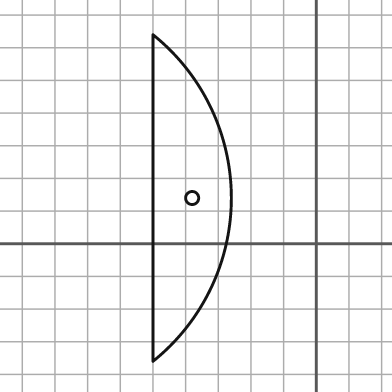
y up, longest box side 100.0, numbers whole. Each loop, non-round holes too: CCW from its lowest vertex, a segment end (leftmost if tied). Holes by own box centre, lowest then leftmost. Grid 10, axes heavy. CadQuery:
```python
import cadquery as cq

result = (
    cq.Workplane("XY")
    .moveTo(-50.0, -36.0)
    .threePointArc((-26.0, 14.0), (-50.0, 64.0))
    .close()
    .moveTo(-38.0, 14.0)
    .circle(2.0)
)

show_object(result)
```